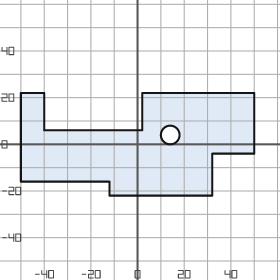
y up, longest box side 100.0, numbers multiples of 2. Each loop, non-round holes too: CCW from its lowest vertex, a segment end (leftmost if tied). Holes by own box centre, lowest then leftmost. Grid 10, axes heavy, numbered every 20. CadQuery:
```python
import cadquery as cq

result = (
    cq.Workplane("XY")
    .moveTo(-12.0, -22.0)
    .lineTo(32.0, -22.0)
    .lineTo(32.0, -4.0)
    .lineTo(50.0, -4.0)
    .lineTo(50.0, 22.0)
    .lineTo(2.0, 22.0)
    .lineTo(2.0, 6.0)
    .lineTo(-40.0, 6.0)
    .lineTo(-40.0, 22.0)
    .lineTo(-50.0, 22.0)
    .lineTo(-50.0, -16.0)
    .lineTo(-12.0, -16.0)
    .close()
    .moveTo(14.0, 4.0)
    .circle(4.0)
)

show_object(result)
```